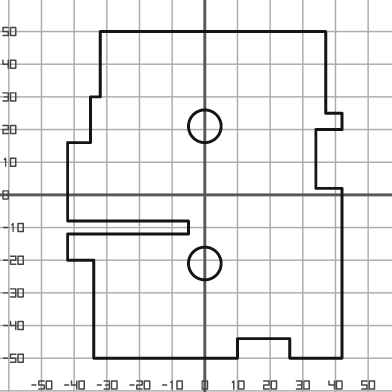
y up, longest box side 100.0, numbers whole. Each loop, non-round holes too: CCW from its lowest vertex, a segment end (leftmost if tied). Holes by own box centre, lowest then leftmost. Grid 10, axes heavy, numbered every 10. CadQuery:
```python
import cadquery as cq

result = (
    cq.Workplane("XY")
    .moveTo(-34.0, -50.0)
    .lineTo(10.0, -50.0)
    .lineTo(10.0, -44.0)
    .lineTo(26.0, -44.0)
    .lineTo(26.0, -50.0)
    .lineTo(42.0, -50.0)
    .lineTo(42.0, 2.0)
    .lineTo(34.0, 2.0)
    .lineTo(34.0, 20.0)
    .lineTo(42.0, 20.0)
    .lineTo(42.0, 25.0)
    .lineTo(37.0, 25.0)
    .lineTo(37.0, 50.0)
    .lineTo(-32.0, 50.0)
    .lineTo(-32.0, 30.0)
    .lineTo(-35.0, 30.0)
    .lineTo(-35.0, 16.0)
    .lineTo(-42.0, 16.0)
    .lineTo(-42.0, -8.0)
    .lineTo(-5.0, -8.0)
    .lineTo(-5.0, -12.0)
    .lineTo(-42.0, -12.0)
    .lineTo(-42.0, -20.0)
    .lineTo(-34.0, -20.0)
    .close()
    .moveTo(0.0, -21.0)
    .circle(5.0)
    .moveTo(0.0, 21.0)
    .circle(5.0)
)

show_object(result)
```